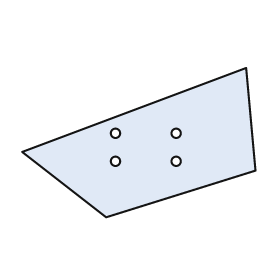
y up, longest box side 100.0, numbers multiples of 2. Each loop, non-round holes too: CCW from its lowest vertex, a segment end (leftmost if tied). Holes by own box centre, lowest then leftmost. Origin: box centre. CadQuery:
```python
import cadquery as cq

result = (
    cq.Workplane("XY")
    .moveTo(-14.0, -32.0)
    .lineTo(50.0, -12.0)
    .lineTo(46.0, 32.0)
    .lineTo(-50.0, -4.0)
    .close()
    .moveTo(-10.0, -8.0)
    .circle(2.0)
    .moveTo(16.0, -8.0)
    .circle(2.0)
    .moveTo(-10.0, 4.0)
    .circle(2.0)
    .moveTo(16.0, 4.0)
    .circle(2.0)
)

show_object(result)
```